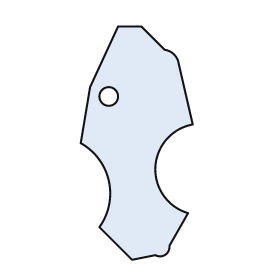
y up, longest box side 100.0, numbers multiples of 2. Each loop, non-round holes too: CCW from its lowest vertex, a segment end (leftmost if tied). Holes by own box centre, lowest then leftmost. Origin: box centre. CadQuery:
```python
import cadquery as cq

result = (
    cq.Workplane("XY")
    .moveTo(-2.0, -50.0)
    .lineTo(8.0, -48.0)
    .threePointArc((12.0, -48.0), (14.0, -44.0))
    .lineTo(22.0, -30.0)
    .threePointArc((8.0, -10.0), (24.0, 8.0))
    .lineTo(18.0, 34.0)
    .threePointArc((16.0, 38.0), (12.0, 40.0))
    .lineTo(2.0, 50.0)
    .lineTo(-8.0, 50.0)
    .lineTo(-20.0, 24.0)
    .lineTo(-24.0, 0.0)
    .threePointArc((-12.0, -16.0), (-16.0, -36.0))
    .close()
    .moveTo(-12.0, 20.0)
    .circle(4.0)
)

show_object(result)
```